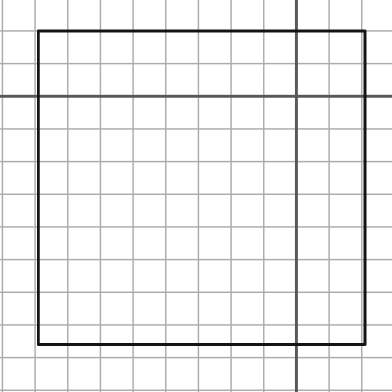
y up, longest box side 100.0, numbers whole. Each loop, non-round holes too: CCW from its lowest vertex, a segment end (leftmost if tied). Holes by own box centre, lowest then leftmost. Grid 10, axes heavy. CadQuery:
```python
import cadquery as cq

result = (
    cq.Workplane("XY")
    .moveTo(-79.0, -76.0)
    .lineTo(21.0, -76.0)
    .lineTo(21.0, 20.0)
    .lineTo(-79.0, 20.0)
    .close()
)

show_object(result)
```